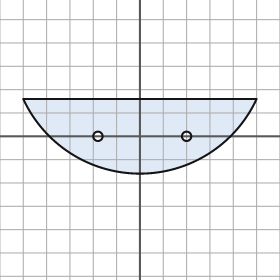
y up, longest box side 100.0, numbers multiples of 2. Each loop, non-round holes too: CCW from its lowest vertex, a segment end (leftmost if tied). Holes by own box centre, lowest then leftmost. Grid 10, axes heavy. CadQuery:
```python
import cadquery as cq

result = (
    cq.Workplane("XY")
    .moveTo(-50.0, 16.0)
    .threePointArc((0.0, -16.0), (50.0, 16.0))
    .close()
    .moveTo(-18.0, 0.0)
    .circle(2.0)
    .moveTo(20.0, 0.0)
    .circle(2.0)
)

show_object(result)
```